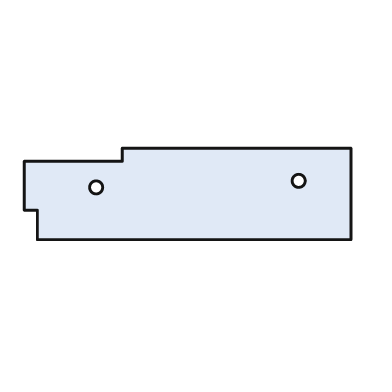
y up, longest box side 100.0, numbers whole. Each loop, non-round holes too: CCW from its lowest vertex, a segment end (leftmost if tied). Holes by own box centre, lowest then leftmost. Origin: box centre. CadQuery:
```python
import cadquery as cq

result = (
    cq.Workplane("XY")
    .moveTo(-46.0, -14.0)
    .lineTo(50.0, -14.0)
    .lineTo(50.0, 14.0)
    .lineTo(-20.0, 14.0)
    .lineTo(-20.0, 10.0)
    .lineTo(-50.0, 10.0)
    .lineTo(-50.0, -5.0)
    .lineTo(-46.0, -5.0)
    .close()
    .moveTo(-28.0, 2.0)
    .circle(2.0)
    .moveTo(34.0, 4.0)
    .circle(2.0)
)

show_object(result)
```